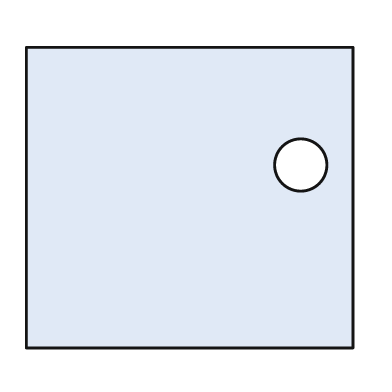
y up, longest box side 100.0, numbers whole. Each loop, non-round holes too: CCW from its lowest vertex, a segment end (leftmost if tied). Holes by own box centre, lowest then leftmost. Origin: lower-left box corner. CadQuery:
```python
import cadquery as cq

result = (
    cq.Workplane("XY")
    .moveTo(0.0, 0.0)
    .lineTo(100.0, 0.0)
    .lineTo(100.0, 92.0)
    .lineTo(0.0, 92.0)
    .close()
    .moveTo(84.0, 56.0)
    .circle(8.0)
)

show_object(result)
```